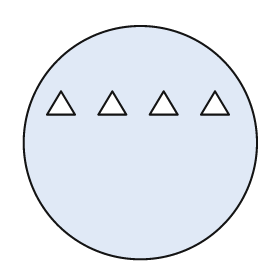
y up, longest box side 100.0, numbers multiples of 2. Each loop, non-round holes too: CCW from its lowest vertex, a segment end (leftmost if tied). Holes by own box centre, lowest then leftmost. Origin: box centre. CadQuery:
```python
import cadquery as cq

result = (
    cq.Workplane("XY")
    .moveTo(0.0, 0.0)
    .circle(50.0)
    .moveTo(-40.0, 12.0)
    .lineTo(-28.0, 12.0)
    .lineTo(-34.0, 22.0)
    .close()
    .moveTo(-18.0, 12.0)
    .lineTo(-6.0, 12.0)
    .lineTo(-12.0, 22.0)
    .close()
    .moveTo(4.0, 12.0)
    .lineTo(16.0, 12.0)
    .lineTo(10.0, 22.0)
    .close()
    .moveTo(26.0, 12.0)
    .lineTo(38.0, 12.0)
    .lineTo(32.0, 22.0)
    .close()
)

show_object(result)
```